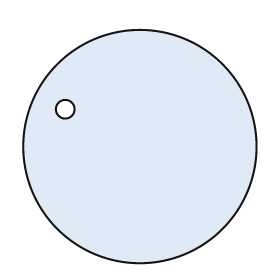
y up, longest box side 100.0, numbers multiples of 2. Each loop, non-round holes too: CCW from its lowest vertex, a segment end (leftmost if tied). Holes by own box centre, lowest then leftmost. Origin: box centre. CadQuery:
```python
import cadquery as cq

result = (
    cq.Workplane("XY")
    .moveTo(0.0, 0.0)
    .circle(50.0)
    .moveTo(-32.0, 16.0)
    .circle(4.0)
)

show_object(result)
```